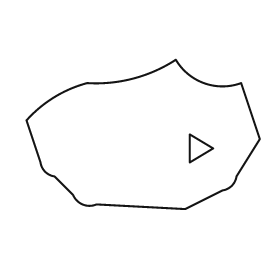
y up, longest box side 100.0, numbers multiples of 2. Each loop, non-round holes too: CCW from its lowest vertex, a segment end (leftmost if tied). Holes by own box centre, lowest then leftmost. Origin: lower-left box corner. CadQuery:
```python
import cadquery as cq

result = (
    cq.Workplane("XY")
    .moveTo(68.0, 0.0)
    .lineTo(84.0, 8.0)
    .threePointArc((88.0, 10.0), (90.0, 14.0))
    .lineTo(100.0, 30.0)
    .lineTo(92.0, 54.0)
    .threePointArc((76.0, 54.0), (64.0, 64.0))
    .threePointArc((46.0, 56.0), (26.0, 54.0))
    .threePointArc((12.0, 48.0), (0.0, 38.0))
    .lineTo(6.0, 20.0)
    .threePointArc((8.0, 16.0), (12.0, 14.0))
    .lineTo(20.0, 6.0)
    .threePointArc((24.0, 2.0), (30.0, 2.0))
    .close()
    .moveTo(70.0, 20.0)
    .lineTo(80.0, 26.0)
    .lineTo(70.0, 32.0)
    .close()
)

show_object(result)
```